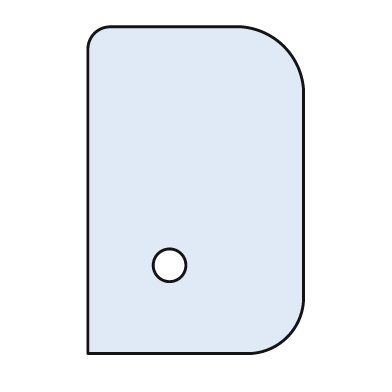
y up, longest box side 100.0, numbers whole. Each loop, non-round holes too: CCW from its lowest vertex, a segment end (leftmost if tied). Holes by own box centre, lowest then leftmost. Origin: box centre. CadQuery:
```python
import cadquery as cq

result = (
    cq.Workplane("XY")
    .moveTo(-33.0, -50.0)
    .lineTo(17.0, -50.0)
    .threePointArc((28.0, -45.0), (33.0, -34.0))
    .lineTo(33.0, 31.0)
    .threePointArc((27.0, 44.0), (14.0, 50.0))
    .lineTo(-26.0, 50.0)
    .threePointArc((-31.0, 48.0), (-33.0, 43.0))
    .close()
    .moveTo(-8.0, -23.0)
    .circle(5.0)
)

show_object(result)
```